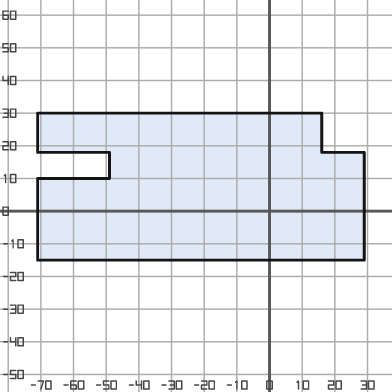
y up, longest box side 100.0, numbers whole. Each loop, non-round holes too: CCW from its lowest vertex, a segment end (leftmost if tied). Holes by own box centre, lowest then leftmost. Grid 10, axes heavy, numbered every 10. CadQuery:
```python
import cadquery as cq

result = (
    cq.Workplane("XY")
    .moveTo(-71.0, -15.0)
    .lineTo(29.0, -15.0)
    .lineTo(29.0, 18.0)
    .lineTo(16.0, 18.0)
    .lineTo(16.0, 30.0)
    .lineTo(-71.0, 30.0)
    .lineTo(-71.0, 18.0)
    .lineTo(-49.0, 18.0)
    .lineTo(-49.0, 10.0)
    .lineTo(-71.0, 10.0)
    .close()
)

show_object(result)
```